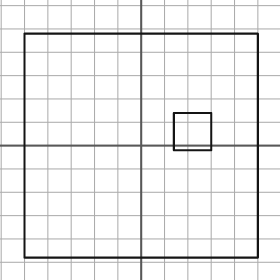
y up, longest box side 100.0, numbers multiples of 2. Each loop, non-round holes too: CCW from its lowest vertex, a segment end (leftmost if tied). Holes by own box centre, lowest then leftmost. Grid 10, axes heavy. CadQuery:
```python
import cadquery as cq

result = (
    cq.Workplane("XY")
    .moveTo(-50.0, -48.0)
    .lineTo(50.0, -48.0)
    .lineTo(50.0, 48.0)
    .lineTo(-50.0, 48.0)
    .close()
    .moveTo(14.0, -2.0)
    .lineTo(30.0, -2.0)
    .lineTo(30.0, 14.0)
    .lineTo(14.0, 14.0)
    .close()
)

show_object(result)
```